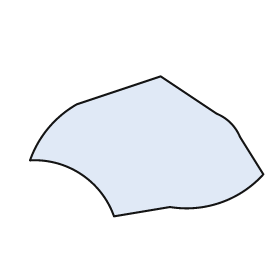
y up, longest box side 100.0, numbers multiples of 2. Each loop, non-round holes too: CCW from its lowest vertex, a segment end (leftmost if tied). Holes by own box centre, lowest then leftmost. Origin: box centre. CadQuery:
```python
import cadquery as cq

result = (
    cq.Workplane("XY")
    .moveTo(-14.0, -30.0)
    .lineTo(10.0, -26.0)
    .threePointArc((32.0, -24.0), (50.0, -12.0))
    .lineTo(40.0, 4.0)
    .threePointArc((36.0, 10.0), (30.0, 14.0))
    .lineTo(6.0, 30.0)
    .lineTo(-30.0, 18.0)
    .threePointArc((-42.0, 8.0), (-50.0, -6.0))
    .threePointArc((-28.0, -12.0), (-14.0, -30.0))
    .close()
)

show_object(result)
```